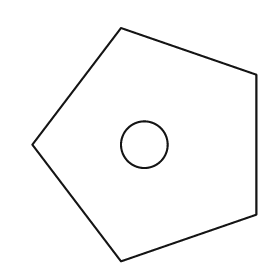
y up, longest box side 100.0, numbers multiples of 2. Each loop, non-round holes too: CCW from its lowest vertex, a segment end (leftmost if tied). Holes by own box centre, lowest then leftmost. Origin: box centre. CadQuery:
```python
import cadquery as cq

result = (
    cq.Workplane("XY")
    .moveTo(-10.0, -50.0)
    .lineTo(48.0, -30.0)
    .lineTo(48.0, 30.0)
    .lineTo(-10.0, 50.0)
    .lineTo(-48.0, 0.0)
    .close()
    .moveTo(0.0, 0.0)
    .circle(10.0)
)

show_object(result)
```